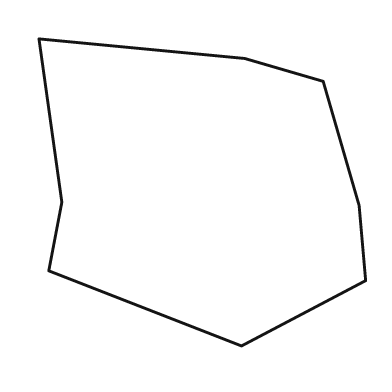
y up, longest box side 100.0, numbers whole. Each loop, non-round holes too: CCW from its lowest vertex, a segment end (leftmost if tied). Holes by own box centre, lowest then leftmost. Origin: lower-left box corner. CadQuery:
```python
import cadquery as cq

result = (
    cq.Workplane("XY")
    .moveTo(62.0, 0.0)
    .lineTo(100.0, 20.0)
    .lineTo(98.0, 43.0)
    .lineTo(87.0, 81.0)
    .lineTo(63.0, 88.0)
    .lineTo(0.0, 94.0)
    .lineTo(7.0, 44.0)
    .lineTo(3.0, 23.0)
    .close()
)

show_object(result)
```